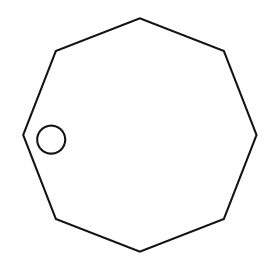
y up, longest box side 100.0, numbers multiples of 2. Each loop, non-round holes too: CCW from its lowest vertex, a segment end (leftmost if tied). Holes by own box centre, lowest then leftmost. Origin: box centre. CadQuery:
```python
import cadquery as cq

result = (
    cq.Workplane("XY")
    .moveTo(0.0, -50.0)
    .lineTo(36.0, -36.0)
    .lineTo(50.0, 0.0)
    .lineTo(36.0, 36.0)
    .lineTo(0.0, 50.0)
    .lineTo(-36.0, 36.0)
    .lineTo(-50.0, 0.0)
    .lineTo(-36.0, -36.0)
    .close()
    .moveTo(-38.0, -2.0)
    .circle(6.0)
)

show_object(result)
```